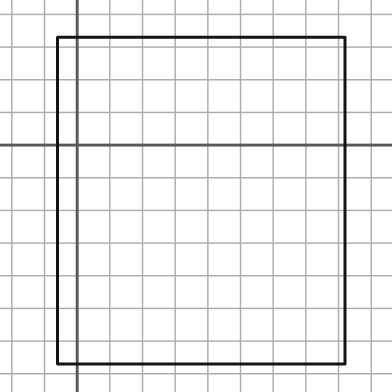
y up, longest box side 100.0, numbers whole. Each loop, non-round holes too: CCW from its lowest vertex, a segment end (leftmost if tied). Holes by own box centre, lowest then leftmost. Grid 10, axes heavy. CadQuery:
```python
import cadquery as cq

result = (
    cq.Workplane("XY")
    .moveTo(-6.0, -67.0)
    .lineTo(82.0, -67.0)
    .lineTo(82.0, 33.0)
    .lineTo(-6.0, 33.0)
    .close()
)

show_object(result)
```